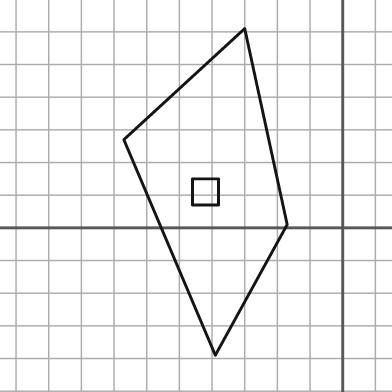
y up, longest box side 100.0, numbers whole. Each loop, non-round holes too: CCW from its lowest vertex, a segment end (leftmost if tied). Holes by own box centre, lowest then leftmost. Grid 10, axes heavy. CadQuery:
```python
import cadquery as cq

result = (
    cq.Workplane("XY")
    .moveTo(-39.0, -39.0)
    .lineTo(-17.0, 1.0)
    .lineTo(-30.0, 61.0)
    .lineTo(-67.0, 27.0)
    .close()
    .moveTo(-46.0, 7.0)
    .lineTo(-38.0, 7.0)
    .lineTo(-38.0, 15.0)
    .lineTo(-46.0, 15.0)
    .close()
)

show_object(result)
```